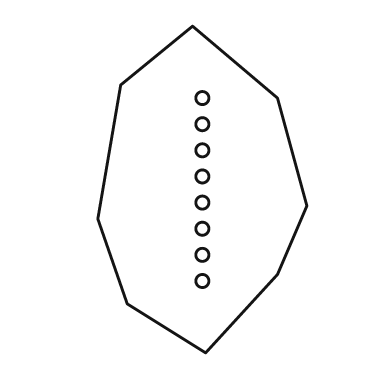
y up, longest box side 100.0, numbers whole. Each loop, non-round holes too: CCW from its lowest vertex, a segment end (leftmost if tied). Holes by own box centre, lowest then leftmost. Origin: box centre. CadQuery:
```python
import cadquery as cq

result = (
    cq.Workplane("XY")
    .moveTo(1.0, -50.0)
    .lineTo(23.0, -26.0)
    .lineTo(32.0, -5.0)
    .lineTo(23.0, 28.0)
    .lineTo(-3.0, 50.0)
    .lineTo(-25.0, 32.0)
    .lineTo(-32.0, -9.0)
    .lineTo(-23.0, -35.0)
    .close()
    .moveTo(0.0, -28.0)
    .circle(2.0)
    .moveTo(0.0, -20.0)
    .circle(2.0)
    .moveTo(0.0, -12.0)
    .circle(2.0)
    .moveTo(0.0, -4.0)
    .circle(2.0)
    .moveTo(0.0, 4.0)
    .circle(2.0)
    .moveTo(0.0, 12.0)
    .circle(2.0)
    .moveTo(0.0, 20.0)
    .circle(2.0)
    .moveTo(0.0, 28.0)
    .circle(2.0)
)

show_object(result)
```